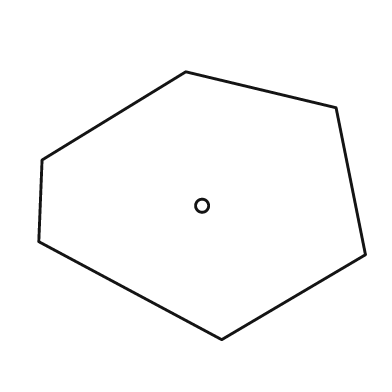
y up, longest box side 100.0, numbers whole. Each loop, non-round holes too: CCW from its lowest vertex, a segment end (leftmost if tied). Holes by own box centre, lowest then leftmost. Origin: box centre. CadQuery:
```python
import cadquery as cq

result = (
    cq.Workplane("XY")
    .moveTo(6.0, -41.0)
    .lineTo(50.0, -15.0)
    .lineTo(41.0, 30.0)
    .lineTo(-5.0, 41.0)
    .lineTo(-49.0, 14.0)
    .lineTo(-50.0, -11.0)
    .close()
    .moveTo(0.0, 0.0)
    .circle(2.0)
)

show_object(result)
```